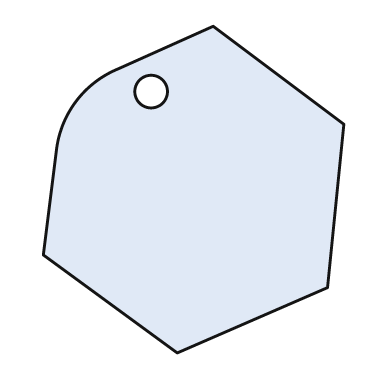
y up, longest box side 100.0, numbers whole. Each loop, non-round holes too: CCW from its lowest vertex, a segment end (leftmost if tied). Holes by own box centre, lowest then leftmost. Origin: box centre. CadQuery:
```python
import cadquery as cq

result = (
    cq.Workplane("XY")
    .moveTo(-5.0, -50.0)
    .lineTo(41.0, -30.0)
    .lineTo(46.0, 20.0)
    .lineTo(6.0, 50.0)
    .lineTo(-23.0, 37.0)
    .threePointArc((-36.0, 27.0), (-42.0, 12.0))
    .lineTo(-46.0, -20.0)
    .close()
    .moveTo(-13.0, 30.0)
    .circle(5.0)
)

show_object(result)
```